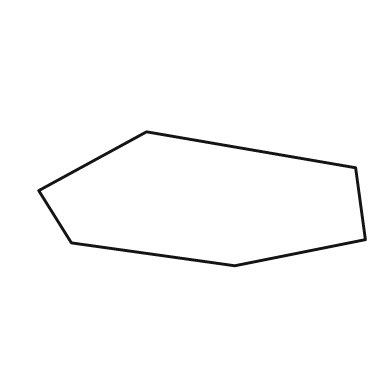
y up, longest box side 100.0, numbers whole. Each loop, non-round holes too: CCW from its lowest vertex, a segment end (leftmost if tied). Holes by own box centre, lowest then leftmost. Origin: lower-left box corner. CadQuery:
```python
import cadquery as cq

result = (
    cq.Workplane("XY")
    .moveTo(60.0, 0.0)
    .lineTo(100.0, 8.0)
    .lineTo(97.0, 30.0)
    .lineTo(33.0, 41.0)
    .lineTo(0.0, 23.0)
    .lineTo(10.0, 7.0)
    .close()
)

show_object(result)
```